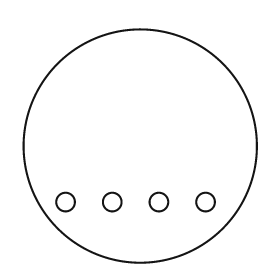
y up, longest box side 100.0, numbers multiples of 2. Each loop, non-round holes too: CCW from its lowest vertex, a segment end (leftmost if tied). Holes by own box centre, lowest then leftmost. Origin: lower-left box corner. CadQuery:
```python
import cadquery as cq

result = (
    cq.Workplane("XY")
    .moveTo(50.0, 50.0)
    .circle(50.0)
    .moveTo(18.0, 26.0)
    .circle(4.0)
    .moveTo(38.0, 26.0)
    .circle(4.0)
    .moveTo(58.0, 26.0)
    .circle(4.0)
    .moveTo(78.0, 26.0)
    .circle(4.0)
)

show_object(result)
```